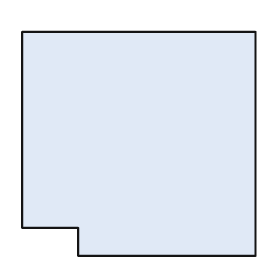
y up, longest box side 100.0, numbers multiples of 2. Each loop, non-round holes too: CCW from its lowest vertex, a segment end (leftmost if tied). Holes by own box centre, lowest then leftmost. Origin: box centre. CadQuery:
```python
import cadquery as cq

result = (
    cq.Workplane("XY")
    .moveTo(-26.0, -48.0)
    .lineTo(50.0, -48.0)
    .lineTo(50.0, 48.0)
    .lineTo(-50.0, 48.0)
    .lineTo(-50.0, -36.0)
    .lineTo(-26.0, -36.0)
    .close()
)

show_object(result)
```